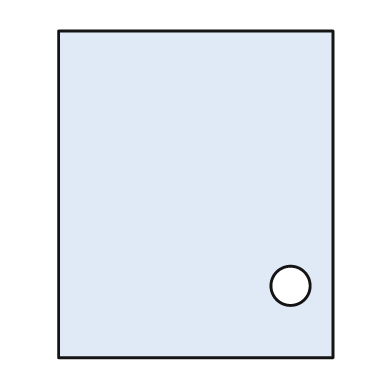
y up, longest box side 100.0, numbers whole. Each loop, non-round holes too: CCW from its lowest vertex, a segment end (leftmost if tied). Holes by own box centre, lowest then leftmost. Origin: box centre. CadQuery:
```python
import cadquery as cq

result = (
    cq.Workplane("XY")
    .moveTo(-42.0, -50.0)
    .lineTo(42.0, -50.0)
    .lineTo(42.0, 50.0)
    .lineTo(-42.0, 50.0)
    .close()
    .moveTo(29.0, -28.0)
    .circle(6.0)
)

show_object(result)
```